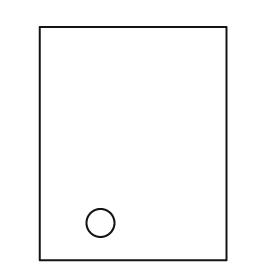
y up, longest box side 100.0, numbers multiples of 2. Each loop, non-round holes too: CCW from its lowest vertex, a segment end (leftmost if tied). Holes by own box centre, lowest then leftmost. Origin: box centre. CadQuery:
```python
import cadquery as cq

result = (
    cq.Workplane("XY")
    .moveTo(-40.0, -50.0)
    .lineTo(40.0, -50.0)
    .lineTo(40.0, 50.0)
    .lineTo(-40.0, 50.0)
    .close()
    .moveTo(-14.0, -34.0)
    .circle(6.0)
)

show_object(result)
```